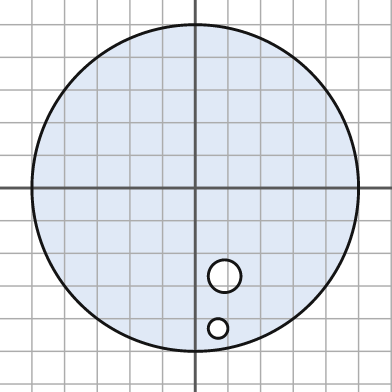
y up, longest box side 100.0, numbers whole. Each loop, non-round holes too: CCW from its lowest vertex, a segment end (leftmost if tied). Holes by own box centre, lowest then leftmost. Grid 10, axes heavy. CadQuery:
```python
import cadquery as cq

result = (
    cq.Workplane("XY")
    .moveTo(0.0, 0.0)
    .circle(50.0)
    .moveTo(7.0, -43.0)
    .circle(3.0)
    .moveTo(9.0, -27.0)
    .circle(5.0)
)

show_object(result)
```